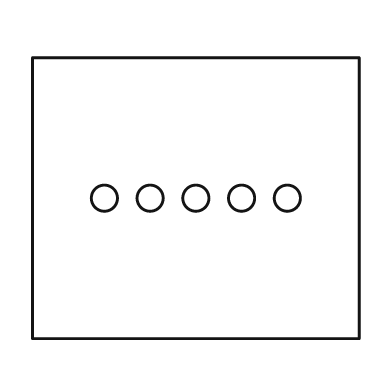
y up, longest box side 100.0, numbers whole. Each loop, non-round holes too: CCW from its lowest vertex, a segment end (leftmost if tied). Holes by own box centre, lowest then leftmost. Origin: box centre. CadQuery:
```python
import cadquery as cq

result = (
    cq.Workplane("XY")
    .moveTo(-50.0, -43.0)
    .lineTo(50.0, -43.0)
    .lineTo(50.0, 43.0)
    .lineTo(-50.0, 43.0)
    .close()
    .moveTo(-28.0, 0.0)
    .circle(4.0)
    .moveTo(-14.0, 0.0)
    .circle(4.0)
    .moveTo(0.0, 0.0)
    .circle(4.0)
    .moveTo(14.0, 0.0)
    .circle(4.0)
    .moveTo(28.0, 0.0)
    .circle(4.0)
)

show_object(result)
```